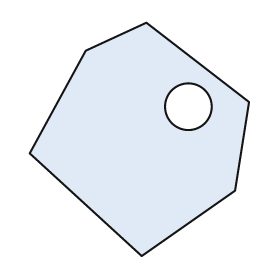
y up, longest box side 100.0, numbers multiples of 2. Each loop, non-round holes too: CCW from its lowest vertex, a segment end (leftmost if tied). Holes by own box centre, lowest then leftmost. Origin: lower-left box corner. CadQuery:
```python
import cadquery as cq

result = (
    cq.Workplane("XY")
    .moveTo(48.0, 0.0)
    .lineTo(88.0, 28.0)
    .lineTo(94.0, 66.0)
    .lineTo(50.0, 100.0)
    .lineTo(24.0, 88.0)
    .lineTo(0.0, 44.0)
    .close()
    .moveTo(68.0, 64.0)
    .circle(10.0)
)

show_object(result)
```